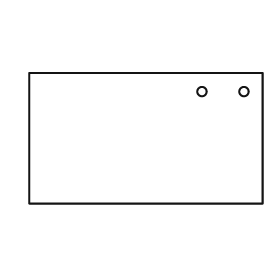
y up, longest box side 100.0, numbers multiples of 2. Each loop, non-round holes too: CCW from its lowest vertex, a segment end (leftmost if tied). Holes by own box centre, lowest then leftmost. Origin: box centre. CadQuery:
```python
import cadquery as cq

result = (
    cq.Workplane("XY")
    .moveTo(-50.0, -28.0)
    .lineTo(50.0, -28.0)
    .lineTo(50.0, 28.0)
    .lineTo(-50.0, 28.0)
    .close()
    .moveTo(24.0, 20.0)
    .circle(2.0)
    .moveTo(42.0, 20.0)
    .circle(2.0)
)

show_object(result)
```